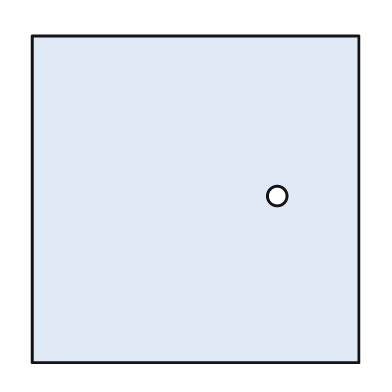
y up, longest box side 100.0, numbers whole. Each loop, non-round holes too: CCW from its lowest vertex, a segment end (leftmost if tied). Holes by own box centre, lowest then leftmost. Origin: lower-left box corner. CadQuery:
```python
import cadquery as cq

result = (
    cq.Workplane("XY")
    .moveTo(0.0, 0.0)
    .lineTo(100.0, 0.0)
    .lineTo(100.0, 100.0)
    .lineTo(0.0, 100.0)
    .close()
    .moveTo(75.0, 51.0)
    .circle(3.0)
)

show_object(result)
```